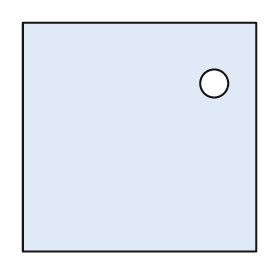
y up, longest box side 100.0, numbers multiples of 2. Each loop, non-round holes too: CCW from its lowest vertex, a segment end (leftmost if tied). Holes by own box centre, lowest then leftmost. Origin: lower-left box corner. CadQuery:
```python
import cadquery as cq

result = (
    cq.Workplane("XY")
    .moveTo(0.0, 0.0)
    .lineTo(100.0, 0.0)
    .lineTo(100.0, 98.0)
    .lineTo(0.0, 98.0)
    .close()
    .moveTo(82.0, 72.0)
    .circle(6.0)
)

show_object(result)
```